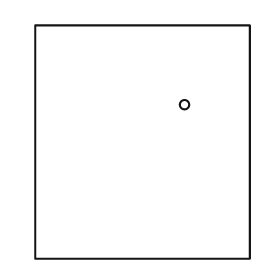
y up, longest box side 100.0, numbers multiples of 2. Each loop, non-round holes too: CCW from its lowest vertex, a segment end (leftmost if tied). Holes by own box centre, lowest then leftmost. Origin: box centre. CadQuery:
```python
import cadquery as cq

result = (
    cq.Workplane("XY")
    .moveTo(-46.0, -50.0)
    .lineTo(46.0, -50.0)
    .lineTo(46.0, 50.0)
    .lineTo(-46.0, 50.0)
    .close()
    .moveTo(18.0, 16.0)
    .circle(2.0)
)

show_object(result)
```